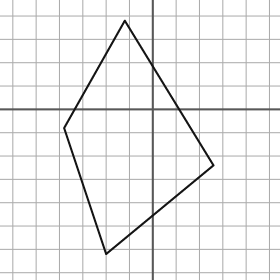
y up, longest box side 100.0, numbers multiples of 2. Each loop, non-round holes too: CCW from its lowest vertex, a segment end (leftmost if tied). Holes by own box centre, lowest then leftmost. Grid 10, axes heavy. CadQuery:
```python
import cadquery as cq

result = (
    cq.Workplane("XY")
    .moveTo(-20.0, -62.0)
    .lineTo(26.0, -24.0)
    .lineTo(-12.0, 38.0)
    .lineTo(-38.0, -8.0)
    .close()
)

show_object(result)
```